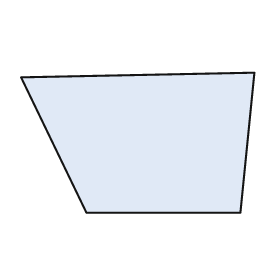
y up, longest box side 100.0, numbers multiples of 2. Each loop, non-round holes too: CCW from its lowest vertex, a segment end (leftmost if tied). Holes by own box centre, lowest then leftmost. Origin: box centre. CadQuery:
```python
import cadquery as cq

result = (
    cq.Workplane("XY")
    .moveTo(-22.0, -30.0)
    .lineTo(44.0, -30.0)
    .lineTo(50.0, 30.0)
    .lineTo(-50.0, 28.0)
    .close()
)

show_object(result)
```